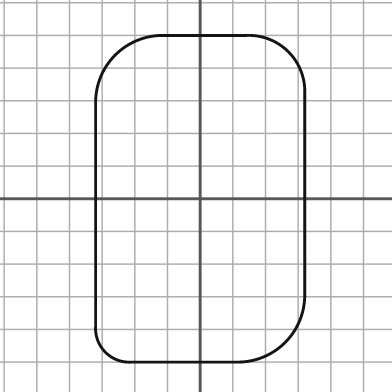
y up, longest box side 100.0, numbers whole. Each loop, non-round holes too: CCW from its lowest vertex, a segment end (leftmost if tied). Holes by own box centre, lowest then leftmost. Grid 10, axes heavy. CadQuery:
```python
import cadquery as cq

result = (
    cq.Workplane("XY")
    .moveTo(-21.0, -50.0)
    .lineTo(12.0, -50.0)
    .threePointArc((26.0, -44.0), (32.0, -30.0))
    .lineTo(32.0, 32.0)
    .threePointArc((27.0, 45.0), (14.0, 50.0))
    .lineTo(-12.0, 50.0)
    .threePointArc((-26.0, 44.0), (-32.0, 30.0))
    .lineTo(-32.0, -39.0)
    .threePointArc((-29.0, -47.0), (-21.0, -50.0))
    .close()
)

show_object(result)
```